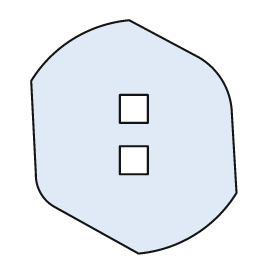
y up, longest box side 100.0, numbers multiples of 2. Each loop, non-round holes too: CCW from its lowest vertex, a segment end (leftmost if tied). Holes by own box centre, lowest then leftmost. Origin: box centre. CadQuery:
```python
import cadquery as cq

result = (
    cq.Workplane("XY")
    .moveTo(2.0, -50.0)
    .threePointArc((26.0, -42.0), (44.0, -24.0))
    .lineTo(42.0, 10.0)
    .threePointArc((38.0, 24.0), (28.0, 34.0))
    .lineTo(-2.0, 50.0)
    .threePointArc((-26.0, 42.0), (-44.0, 24.0))
    .lineTo(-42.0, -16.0)
    .threePointArc((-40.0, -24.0), (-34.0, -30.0))
    .close()
    .moveTo(-6.0, -16.0)
    .lineTo(6.0, -16.0)
    .lineTo(6.0, -4.0)
    .lineTo(-6.0, -4.0)
    .close()
    .moveTo(-6.0, 6.0)
    .lineTo(6.0, 6.0)
    .lineTo(6.0, 18.0)
    .lineTo(-6.0, 18.0)
    .close()
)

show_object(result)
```